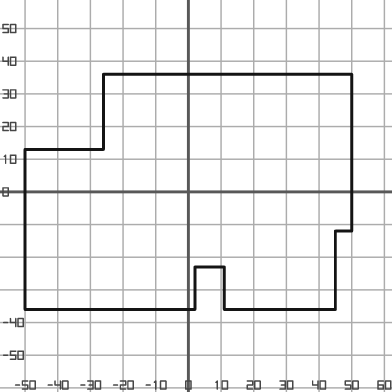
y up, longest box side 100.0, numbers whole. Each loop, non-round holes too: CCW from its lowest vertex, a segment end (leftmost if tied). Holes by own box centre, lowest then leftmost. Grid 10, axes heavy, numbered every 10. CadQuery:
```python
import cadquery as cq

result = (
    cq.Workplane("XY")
    .moveTo(-50.0, -36.0)
    .lineTo(2.0, -36.0)
    .lineTo(2.0, -23.0)
    .lineTo(11.0, -23.0)
    .lineTo(11.0, -36.0)
    .lineTo(45.0, -36.0)
    .lineTo(45.0, -12.0)
    .lineTo(50.0, -12.0)
    .lineTo(50.0, 36.0)
    .lineTo(-26.0, 36.0)
    .lineTo(-26.0, 13.0)
    .lineTo(-50.0, 13.0)
    .close()
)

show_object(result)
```